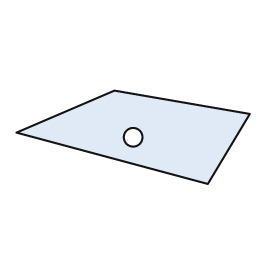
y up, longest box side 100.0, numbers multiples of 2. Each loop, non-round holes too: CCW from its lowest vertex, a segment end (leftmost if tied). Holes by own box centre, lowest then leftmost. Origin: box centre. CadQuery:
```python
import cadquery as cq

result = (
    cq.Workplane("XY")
    .moveTo(32.0, -20.0)
    .lineTo(50.0, 10.0)
    .lineTo(-8.0, 20.0)
    .lineTo(-50.0, 2.0)
    .close()
    .moveTo(0.0, 0.0)
    .circle(4.0)
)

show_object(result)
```